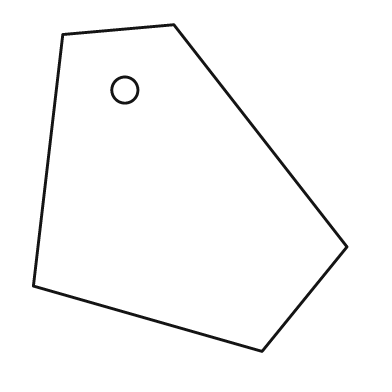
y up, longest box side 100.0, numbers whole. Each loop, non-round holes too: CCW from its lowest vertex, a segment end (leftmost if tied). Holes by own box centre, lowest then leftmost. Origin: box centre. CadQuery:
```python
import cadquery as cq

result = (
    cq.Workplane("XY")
    .moveTo(22.0, -50.0)
    .lineTo(48.0, -18.0)
    .lineTo(-5.0, 50.0)
    .lineTo(-39.0, 47.0)
    .lineTo(-48.0, -30.0)
    .close()
    .moveTo(-20.0, 30.0)
    .circle(4.0)
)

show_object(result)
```